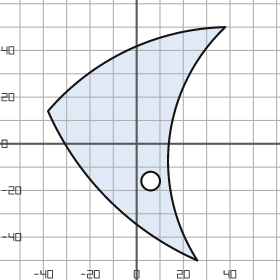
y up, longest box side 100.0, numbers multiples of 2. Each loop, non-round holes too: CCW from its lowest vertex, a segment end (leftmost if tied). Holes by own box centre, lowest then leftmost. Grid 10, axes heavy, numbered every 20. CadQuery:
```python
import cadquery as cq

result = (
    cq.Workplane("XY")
    .moveTo(26.0, -50.0)
    .threePointArc((14.0, 2.0), (38.0, 50.0))
    .threePointArc((-4.0, 40.0), (-38.0, 14.0))
    .threePointArc((-12.0, -24.0), (26.0, -50.0))
    .close()
    .moveTo(6.0, -16.0)
    .circle(4.0)
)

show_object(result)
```